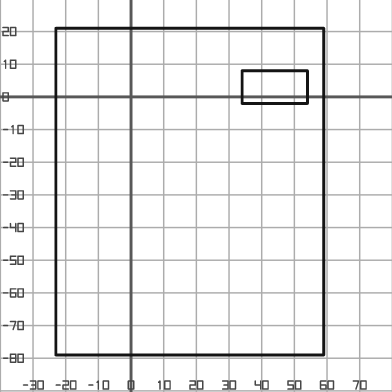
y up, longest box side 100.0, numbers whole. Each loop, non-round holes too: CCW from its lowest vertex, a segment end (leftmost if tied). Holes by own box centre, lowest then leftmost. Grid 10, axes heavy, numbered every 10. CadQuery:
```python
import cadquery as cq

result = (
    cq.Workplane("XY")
    .moveTo(-23.0, -79.0)
    .lineTo(59.0, -79.0)
    .lineTo(59.0, 21.0)
    .lineTo(-23.0, 21.0)
    .close()
    .moveTo(34.0, -2.0)
    .lineTo(54.0, -2.0)
    .lineTo(54.0, 8.0)
    .lineTo(34.0, 8.0)
    .close()
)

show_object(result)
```